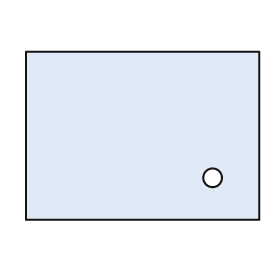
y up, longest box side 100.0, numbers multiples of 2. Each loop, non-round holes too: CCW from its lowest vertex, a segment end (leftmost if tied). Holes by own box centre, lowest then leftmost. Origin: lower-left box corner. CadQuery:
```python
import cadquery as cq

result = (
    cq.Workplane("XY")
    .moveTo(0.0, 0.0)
    .lineTo(100.0, 0.0)
    .lineTo(100.0, 72.0)
    .lineTo(0.0, 72.0)
    .close()
    .moveTo(80.0, 18.0)
    .circle(4.0)
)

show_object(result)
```